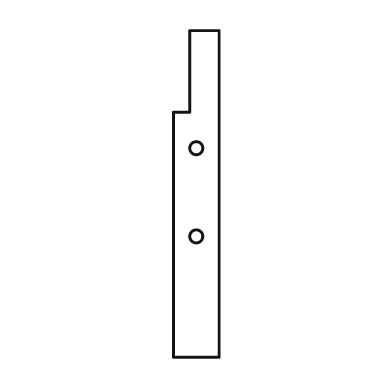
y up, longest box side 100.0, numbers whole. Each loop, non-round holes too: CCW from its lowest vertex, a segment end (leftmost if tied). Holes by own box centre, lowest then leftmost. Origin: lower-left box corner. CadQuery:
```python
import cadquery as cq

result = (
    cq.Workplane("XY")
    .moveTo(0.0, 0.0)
    .lineTo(14.0, 0.0)
    .lineTo(14.0, 100.0)
    .lineTo(5.0, 100.0)
    .lineTo(5.0, 75.0)
    .lineTo(0.0, 75.0)
    .close()
    .moveTo(7.0, 37.0)
    .circle(2.0)
    .moveTo(7.0, 64.0)
    .circle(2.0)
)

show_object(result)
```